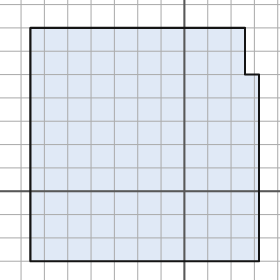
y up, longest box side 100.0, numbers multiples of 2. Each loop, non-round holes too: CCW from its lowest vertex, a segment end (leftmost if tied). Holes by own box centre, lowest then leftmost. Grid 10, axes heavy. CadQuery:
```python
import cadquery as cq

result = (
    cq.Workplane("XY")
    .moveTo(-66.0, -30.0)
    .lineTo(32.0, -30.0)
    .lineTo(32.0, 50.0)
    .lineTo(26.0, 50.0)
    .lineTo(26.0, 70.0)
    .lineTo(-66.0, 70.0)
    .close()
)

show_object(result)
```